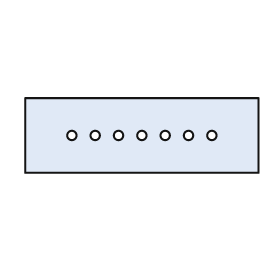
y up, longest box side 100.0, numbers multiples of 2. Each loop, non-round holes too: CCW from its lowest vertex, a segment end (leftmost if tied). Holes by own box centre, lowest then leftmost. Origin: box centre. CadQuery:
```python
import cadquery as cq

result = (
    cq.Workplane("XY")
    .moveTo(-50.0, -16.0)
    .lineTo(50.0, -16.0)
    .lineTo(50.0, 16.0)
    .lineTo(-50.0, 16.0)
    .close()
    .moveTo(-30.0, 0.0)
    .circle(2.0)
    .moveTo(-20.0, 0.0)
    .circle(2.0)
    .moveTo(-10.0, 0.0)
    .circle(2.0)
    .moveTo(0.0, 0.0)
    .circle(2.0)
    .moveTo(10.0, 0.0)
    .circle(2.0)
    .moveTo(20.0, 0.0)
    .circle(2.0)
    .moveTo(30.0, 0.0)
    .circle(2.0)
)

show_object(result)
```